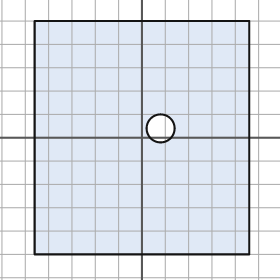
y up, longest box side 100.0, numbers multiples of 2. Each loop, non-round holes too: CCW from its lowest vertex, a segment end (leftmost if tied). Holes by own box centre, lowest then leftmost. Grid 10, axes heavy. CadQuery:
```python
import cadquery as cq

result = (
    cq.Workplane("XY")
    .moveTo(-46.0, -50.0)
    .lineTo(46.0, -50.0)
    .lineTo(46.0, 50.0)
    .lineTo(-46.0, 50.0)
    .close()
    .moveTo(8.0, 4.0)
    .circle(6.0)
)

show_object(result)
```